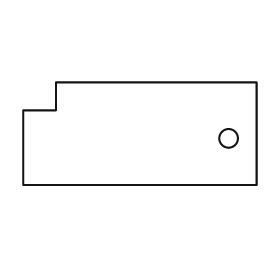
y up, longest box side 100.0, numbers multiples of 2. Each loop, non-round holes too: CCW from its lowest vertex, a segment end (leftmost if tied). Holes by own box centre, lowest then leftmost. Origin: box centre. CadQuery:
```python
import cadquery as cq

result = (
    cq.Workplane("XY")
    .moveTo(-50.0, -22.0)
    .lineTo(50.0, -22.0)
    .lineTo(50.0, 22.0)
    .lineTo(-36.0, 22.0)
    .lineTo(-36.0, 10.0)
    .lineTo(-50.0, 10.0)
    .close()
    .moveTo(38.0, -2.0)
    .circle(4.0)
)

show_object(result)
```